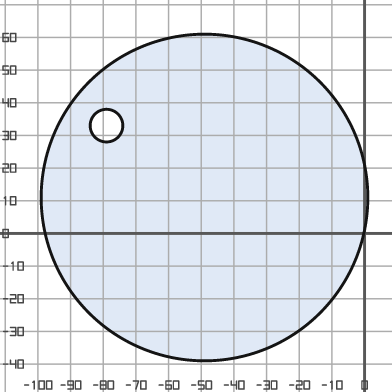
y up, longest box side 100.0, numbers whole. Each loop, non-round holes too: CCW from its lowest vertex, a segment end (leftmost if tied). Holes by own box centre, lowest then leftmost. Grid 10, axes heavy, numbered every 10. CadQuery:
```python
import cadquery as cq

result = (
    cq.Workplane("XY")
    .moveTo(-49.0, 11.0)
    .circle(50.0)
    .moveTo(-79.0, 33.0)
    .circle(5.0)
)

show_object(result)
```